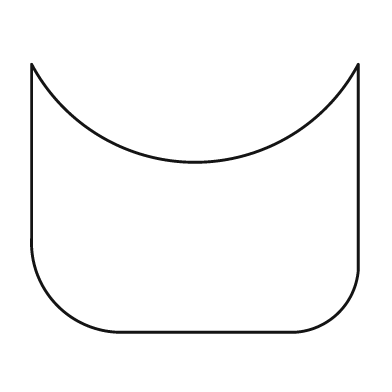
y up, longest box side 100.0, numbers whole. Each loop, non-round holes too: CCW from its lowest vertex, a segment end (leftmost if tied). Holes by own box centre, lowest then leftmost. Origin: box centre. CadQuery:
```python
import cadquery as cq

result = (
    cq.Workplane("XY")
    .moveTo(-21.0, -41.0)
    .lineTo(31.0, -41.0)
    .threePointArc((44.0, -35.0), (50.0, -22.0))
    .lineTo(50.0, 41.0)
    .threePointArc((0.0, 11.0), (-50.0, 41.0))
    .lineTo(-50.0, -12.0)
    .threePointArc((-42.0, -33.0), (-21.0, -41.0))
    .close()
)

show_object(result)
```